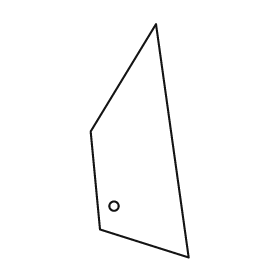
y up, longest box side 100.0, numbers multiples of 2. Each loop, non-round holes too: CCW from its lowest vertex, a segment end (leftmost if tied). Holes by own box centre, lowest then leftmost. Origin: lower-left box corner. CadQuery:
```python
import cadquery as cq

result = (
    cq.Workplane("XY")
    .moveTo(42.0, 0.0)
    .lineTo(28.0, 100.0)
    .lineTo(0.0, 54.0)
    .lineTo(4.0, 12.0)
    .close()
    .moveTo(10.0, 22.0)
    .circle(2.0)
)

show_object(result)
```